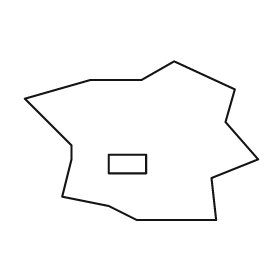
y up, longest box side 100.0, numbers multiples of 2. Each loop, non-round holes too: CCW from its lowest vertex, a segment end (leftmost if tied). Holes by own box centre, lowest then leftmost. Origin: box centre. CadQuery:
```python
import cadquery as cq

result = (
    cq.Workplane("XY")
    .moveTo(-2.0, -34.0)
    .lineTo(32.0, -34.0)
    .lineTo(30.0, -16.0)
    .lineTo(50.0, -8.0)
    .lineTo(36.0, 8.0)
    .lineTo(40.0, 22.0)
    .lineTo(14.0, 34.0)
    .lineTo(0.0, 26.0)
    .lineTo(-22.0, 26.0)
    .lineTo(-50.0, 18.0)
    .lineTo(-30.0, -2.0)
    .lineTo(-30.0, -8.0)
    .lineTo(-34.0, -24.0)
    .lineTo(-14.0, -28.0)
    .close()
    .moveTo(-14.0, -14.0)
    .lineTo(2.0, -14.0)
    .lineTo(2.0, -6.0)
    .lineTo(-14.0, -6.0)
    .close()
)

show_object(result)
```